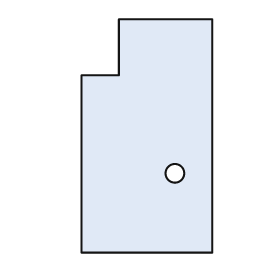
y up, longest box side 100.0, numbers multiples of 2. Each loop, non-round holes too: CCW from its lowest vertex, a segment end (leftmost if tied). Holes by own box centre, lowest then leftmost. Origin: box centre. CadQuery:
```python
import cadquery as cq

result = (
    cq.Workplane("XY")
    .moveTo(-28.0, -50.0)
    .lineTo(28.0, -50.0)
    .lineTo(28.0, 50.0)
    .lineTo(-12.0, 50.0)
    .lineTo(-12.0, 26.0)
    .lineTo(-28.0, 26.0)
    .close()
    .moveTo(12.0, -16.0)
    .circle(4.0)
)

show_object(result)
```